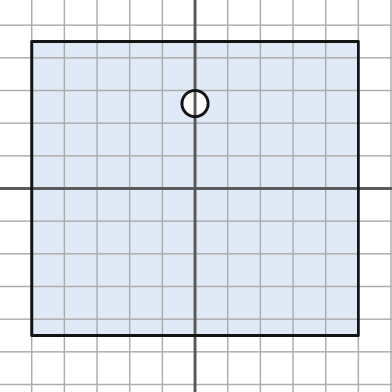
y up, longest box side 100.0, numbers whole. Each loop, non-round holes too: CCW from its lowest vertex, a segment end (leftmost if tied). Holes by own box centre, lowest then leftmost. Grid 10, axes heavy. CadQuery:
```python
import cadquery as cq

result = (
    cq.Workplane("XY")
    .moveTo(-50.0, -45.0)
    .lineTo(50.0, -45.0)
    .lineTo(50.0, 45.0)
    .lineTo(-50.0, 45.0)
    .close()
    .moveTo(0.0, 26.0)
    .circle(4.0)
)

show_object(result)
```